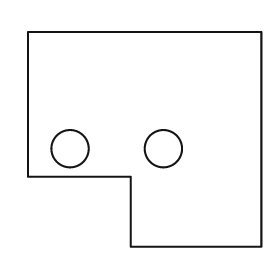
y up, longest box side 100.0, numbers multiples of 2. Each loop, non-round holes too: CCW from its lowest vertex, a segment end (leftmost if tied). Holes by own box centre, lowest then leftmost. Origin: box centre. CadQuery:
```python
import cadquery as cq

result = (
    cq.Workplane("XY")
    .moveTo(-6.0, -46.0)
    .lineTo(50.0, -46.0)
    .lineTo(50.0, 46.0)
    .lineTo(-50.0, 46.0)
    .lineTo(-50.0, -16.0)
    .lineTo(-6.0, -16.0)
    .close()
    .moveTo(-32.0, -4.0)
    .circle(8.0)
    .moveTo(8.0, -4.0)
    .circle(8.0)
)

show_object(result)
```